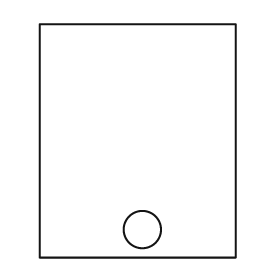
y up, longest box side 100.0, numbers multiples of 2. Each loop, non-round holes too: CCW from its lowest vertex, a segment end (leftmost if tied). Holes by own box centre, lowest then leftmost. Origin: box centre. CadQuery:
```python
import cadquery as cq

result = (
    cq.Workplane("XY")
    .moveTo(-42.0, -50.0)
    .lineTo(42.0, -50.0)
    .lineTo(42.0, 50.0)
    .lineTo(-42.0, 50.0)
    .close()
    .moveTo(2.0, -38.0)
    .circle(8.0)
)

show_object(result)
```